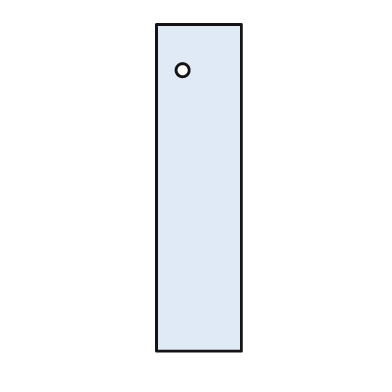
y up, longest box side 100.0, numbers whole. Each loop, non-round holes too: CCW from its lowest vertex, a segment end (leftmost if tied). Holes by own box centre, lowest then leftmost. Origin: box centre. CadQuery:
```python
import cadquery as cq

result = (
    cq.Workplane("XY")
    .moveTo(-13.0, -50.0)
    .lineTo(13.0, -50.0)
    .lineTo(13.0, 50.0)
    .lineTo(-13.0, 50.0)
    .close()
    .moveTo(-5.0, 36.0)
    .circle(2.0)
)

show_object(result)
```